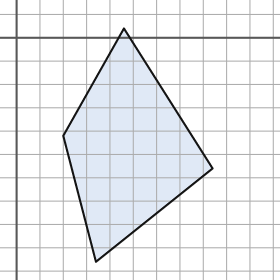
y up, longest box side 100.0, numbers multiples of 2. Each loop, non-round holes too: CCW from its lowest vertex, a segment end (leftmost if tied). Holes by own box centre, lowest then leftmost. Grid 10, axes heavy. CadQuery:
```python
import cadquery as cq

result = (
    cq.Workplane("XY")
    .moveTo(34.0, -96.0)
    .lineTo(84.0, -56.0)
    .lineTo(46.0, 4.0)
    .lineTo(20.0, -42.0)
    .close()
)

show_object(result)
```